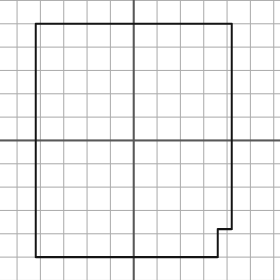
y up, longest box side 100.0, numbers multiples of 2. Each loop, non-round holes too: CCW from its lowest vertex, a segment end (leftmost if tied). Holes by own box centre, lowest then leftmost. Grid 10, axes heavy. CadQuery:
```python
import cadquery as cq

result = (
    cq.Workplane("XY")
    .moveTo(-42.0, -50.0)
    .lineTo(36.0, -50.0)
    .lineTo(36.0, -38.0)
    .lineTo(42.0, -38.0)
    .lineTo(42.0, 50.0)
    .lineTo(-42.0, 50.0)
    .close()
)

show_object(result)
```